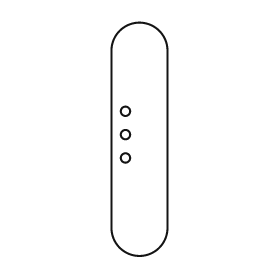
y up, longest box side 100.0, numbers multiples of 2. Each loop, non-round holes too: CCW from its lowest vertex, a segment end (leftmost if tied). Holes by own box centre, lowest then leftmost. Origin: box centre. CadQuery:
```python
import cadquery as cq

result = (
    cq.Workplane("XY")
    .moveTo(-12.0, -38.0)
    .threePointArc((0.0, -50.0), (12.0, -38.0))
    .lineTo(12.0, 38.0)
    .threePointArc((0.0, 50.0), (-12.0, 38.0))
    .close()
    .moveTo(-6.0, -8.0)
    .circle(2.0)
    .moveTo(-6.0, 2.0)
    .circle(2.0)
    .moveTo(-6.0, 12.0)
    .circle(2.0)
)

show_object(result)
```